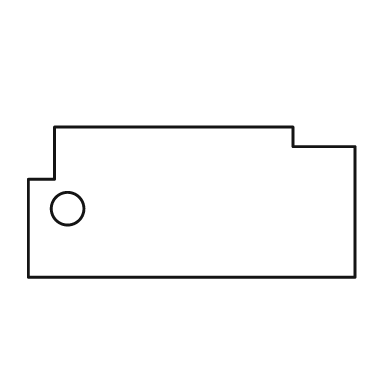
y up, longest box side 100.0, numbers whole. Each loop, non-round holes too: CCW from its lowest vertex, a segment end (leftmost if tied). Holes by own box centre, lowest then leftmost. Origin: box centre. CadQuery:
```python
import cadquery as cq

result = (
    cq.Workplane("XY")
    .moveTo(-50.0, -23.0)
    .lineTo(50.0, -23.0)
    .lineTo(50.0, 17.0)
    .lineTo(31.0, 17.0)
    .lineTo(31.0, 23.0)
    .lineTo(-42.0, 23.0)
    .lineTo(-42.0, 7.0)
    .lineTo(-50.0, 7.0)
    .close()
    .moveTo(-38.0, -2.0)
    .circle(5.0)
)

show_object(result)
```